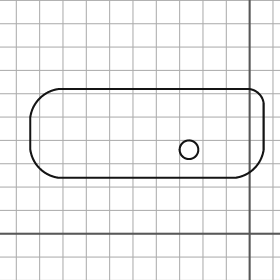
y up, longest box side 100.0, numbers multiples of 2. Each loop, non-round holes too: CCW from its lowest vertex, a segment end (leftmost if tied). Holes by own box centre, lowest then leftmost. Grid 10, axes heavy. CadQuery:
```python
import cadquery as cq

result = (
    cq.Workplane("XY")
    .moveTo(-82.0, 24.0)
    .lineTo(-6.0, 24.0)
    .threePointArc((2.0, 28.0), (6.0, 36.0))
    .lineTo(6.0, 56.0)
    .threePointArc((4.0, 60.0), (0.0, 62.0))
    .lineTo(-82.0, 62.0)
    .threePointArc((-90.0, 58.0), (-94.0, 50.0))
    .lineTo(-94.0, 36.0)
    .threePointArc((-90.0, 28.0), (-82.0, 24.0))
    .close()
    .moveTo(-26.0, 36.0)
    .circle(4.0)
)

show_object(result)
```